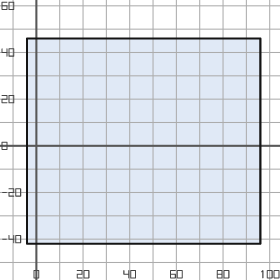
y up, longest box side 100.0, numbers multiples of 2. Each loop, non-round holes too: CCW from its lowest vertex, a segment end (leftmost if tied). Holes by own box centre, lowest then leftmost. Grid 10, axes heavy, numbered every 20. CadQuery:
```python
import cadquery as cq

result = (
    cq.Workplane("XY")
    .moveTo(-4.0, -42.0)
    .lineTo(96.0, -42.0)
    .lineTo(96.0, 46.0)
    .lineTo(-4.0, 46.0)
    .close()
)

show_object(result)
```